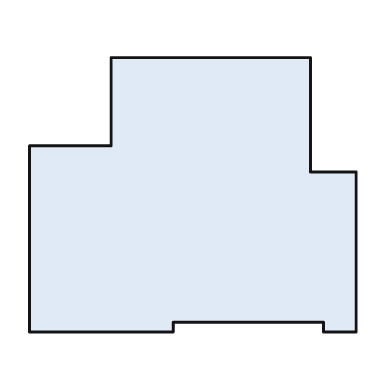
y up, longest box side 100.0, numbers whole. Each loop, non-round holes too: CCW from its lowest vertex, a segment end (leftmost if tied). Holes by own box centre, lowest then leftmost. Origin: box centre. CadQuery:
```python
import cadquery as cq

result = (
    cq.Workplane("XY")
    .moveTo(-50.0, -42.0)
    .lineTo(-6.0, -42.0)
    .lineTo(-6.0, -39.0)
    .lineTo(40.0, -39.0)
    .lineTo(40.0, -42.0)
    .lineTo(50.0, -42.0)
    .lineTo(50.0, 7.0)
    .lineTo(36.0, 7.0)
    .lineTo(36.0, 42.0)
    .lineTo(-25.0, 42.0)
    .lineTo(-25.0, 15.0)
    .lineTo(-50.0, 15.0)
    .close()
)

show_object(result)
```